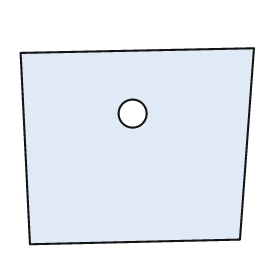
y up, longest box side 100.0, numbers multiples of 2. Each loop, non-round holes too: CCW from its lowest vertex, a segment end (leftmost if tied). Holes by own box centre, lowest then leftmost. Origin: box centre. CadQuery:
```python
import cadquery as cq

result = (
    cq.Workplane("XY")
    .moveTo(-46.0, -42.0)
    .lineTo(44.0, -40.0)
    .lineTo(50.0, 42.0)
    .lineTo(-50.0, 40.0)
    .close()
    .moveTo(-2.0, 14.0)
    .circle(6.0)
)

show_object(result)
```